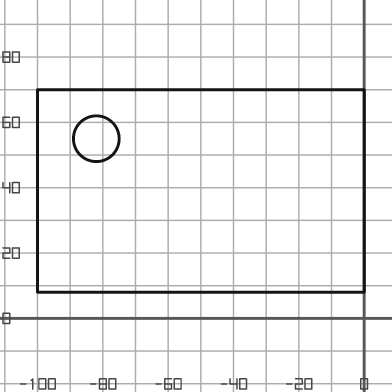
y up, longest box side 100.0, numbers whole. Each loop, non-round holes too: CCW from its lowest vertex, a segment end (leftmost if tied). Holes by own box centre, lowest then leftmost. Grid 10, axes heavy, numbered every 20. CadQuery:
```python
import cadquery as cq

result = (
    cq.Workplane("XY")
    .moveTo(-100.0, 8.0)
    .lineTo(0.0, 8.0)
    .lineTo(0.0, 70.0)
    .lineTo(-100.0, 70.0)
    .close()
    .moveTo(-82.0, 55.0)
    .circle(7.0)
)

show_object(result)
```